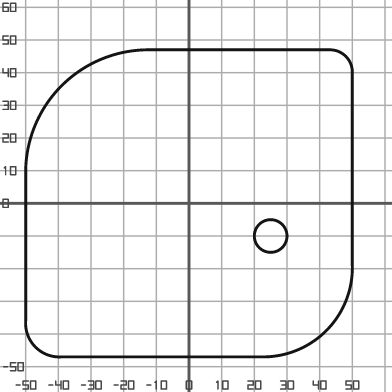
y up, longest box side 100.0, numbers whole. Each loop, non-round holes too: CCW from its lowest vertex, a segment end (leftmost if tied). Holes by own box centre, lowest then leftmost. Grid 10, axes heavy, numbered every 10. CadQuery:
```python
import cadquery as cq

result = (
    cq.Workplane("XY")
    .moveTo(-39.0, -47.0)
    .lineTo(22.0, -47.0)
    .threePointArc((42.0, -39.0), (50.0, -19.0))
    .lineTo(50.0, 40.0)
    .threePointArc((48.0, 45.0), (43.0, 47.0))
    .lineTo(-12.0, 47.0)
    .threePointArc((-39.0, 36.0), (-50.0, 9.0))
    .lineTo(-50.0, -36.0)
    .threePointArc((-47.0, -44.0), (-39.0, -47.0))
    .close()
    .moveTo(25.0, -10.0)
    .circle(5.0)
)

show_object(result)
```